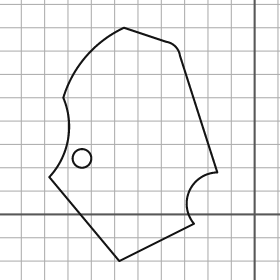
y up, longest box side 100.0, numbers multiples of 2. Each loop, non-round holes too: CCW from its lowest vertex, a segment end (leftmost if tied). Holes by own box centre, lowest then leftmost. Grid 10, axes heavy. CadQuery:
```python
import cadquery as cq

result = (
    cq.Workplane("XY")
    .moveTo(-58.0, -20.0)
    .lineTo(-26.0, -4.0)
    .threePointArc((-28.0, 10.0), (-16.0, 18.0))
    .lineTo(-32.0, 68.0)
    .threePointArc((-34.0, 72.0), (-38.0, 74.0))
    .lineTo(-56.0, 80.0)
    .threePointArc((-72.0, 68.0), (-82.0, 50.0))
    .threePointArc((-80.0, 32.0), (-88.0, 16.0))
    .close()
    .moveTo(-74.0, 24.0)
    .circle(4.0)
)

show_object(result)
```